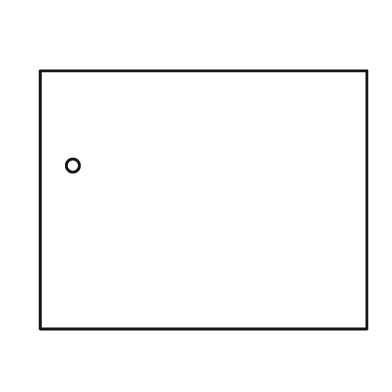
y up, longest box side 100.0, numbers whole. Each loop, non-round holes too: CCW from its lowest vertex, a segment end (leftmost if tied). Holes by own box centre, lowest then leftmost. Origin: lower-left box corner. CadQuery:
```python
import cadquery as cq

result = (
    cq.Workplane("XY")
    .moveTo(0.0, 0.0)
    .lineTo(100.0, 0.0)
    .lineTo(100.0, 79.0)
    .lineTo(0.0, 79.0)
    .close()
    .moveTo(10.0, 50.0)
    .circle(2.0)
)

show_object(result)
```